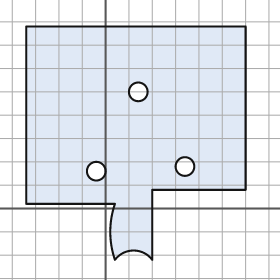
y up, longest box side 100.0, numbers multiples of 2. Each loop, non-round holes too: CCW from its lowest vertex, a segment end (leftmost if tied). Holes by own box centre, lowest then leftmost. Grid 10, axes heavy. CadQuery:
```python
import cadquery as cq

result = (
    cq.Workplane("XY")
    .moveTo(4.0, -22.0)
    .threePointArc((12.0, -18.0), (20.0, -22.0))
    .lineTo(20.0, 8.0)
    .lineTo(60.0, 8.0)
    .lineTo(60.0, 78.0)
    .lineTo(-34.0, 78.0)
    .lineTo(-34.0, 2.0)
    .lineTo(4.0, 2.0)
    .threePointArc((2.0, -10.0), (4.0, -22.0))
    .close()
    .moveTo(-4.0, 16.0)
    .circle(4.0)
    .moveTo(34.0, 18.0)
    .circle(4.0)
    .moveTo(14.0, 50.0)
    .circle(4.0)
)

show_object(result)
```